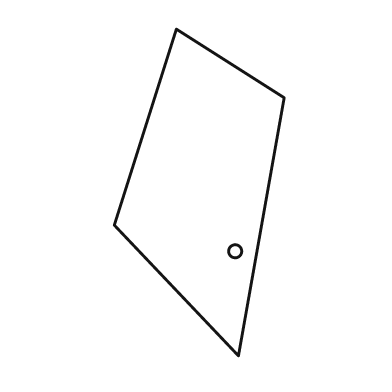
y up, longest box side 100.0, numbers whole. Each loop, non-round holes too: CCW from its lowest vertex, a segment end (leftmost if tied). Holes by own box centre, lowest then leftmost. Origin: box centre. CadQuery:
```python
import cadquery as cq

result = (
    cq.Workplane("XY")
    .moveTo(12.0, -50.0)
    .lineTo(26.0, 29.0)
    .lineTo(-7.0, 50.0)
    .lineTo(-26.0, -10.0)
    .close()
    .moveTo(11.0, -18.0)
    .circle(2.0)
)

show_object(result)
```